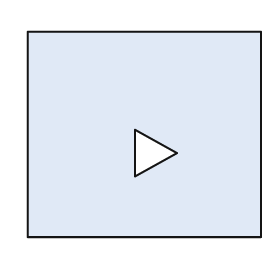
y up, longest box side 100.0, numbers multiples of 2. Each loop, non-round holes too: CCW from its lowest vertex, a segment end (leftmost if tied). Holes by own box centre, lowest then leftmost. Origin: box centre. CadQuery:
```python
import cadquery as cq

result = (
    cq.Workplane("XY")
    .moveTo(-50.0, -44.0)
    .lineTo(50.0, -44.0)
    .lineTo(50.0, 44.0)
    .lineTo(-50.0, 44.0)
    .close()
    .moveTo(-4.0, -18.0)
    .lineTo(14.0, -8.0)
    .lineTo(-4.0, 2.0)
    .close()
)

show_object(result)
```